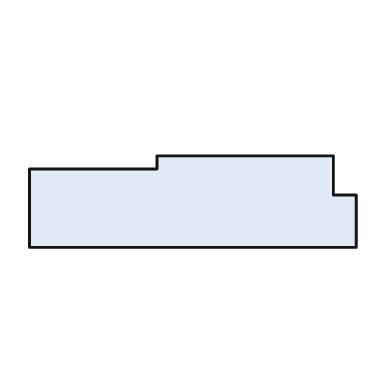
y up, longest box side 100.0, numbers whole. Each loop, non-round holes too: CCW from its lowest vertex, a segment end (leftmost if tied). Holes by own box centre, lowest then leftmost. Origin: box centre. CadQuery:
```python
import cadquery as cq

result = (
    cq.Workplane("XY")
    .moveTo(-50.0, -14.0)
    .lineTo(50.0, -14.0)
    .lineTo(50.0, 2.0)
    .lineTo(43.0, 2.0)
    .lineTo(43.0, 14.0)
    .lineTo(-11.0, 14.0)
    .lineTo(-11.0, 10.0)
    .lineTo(-50.0, 10.0)
    .close()
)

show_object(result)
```